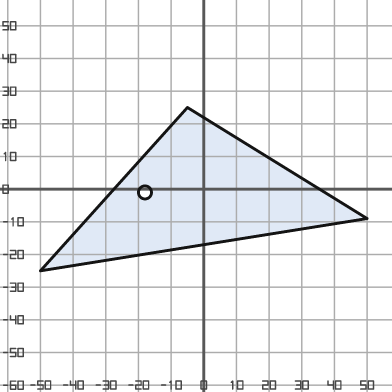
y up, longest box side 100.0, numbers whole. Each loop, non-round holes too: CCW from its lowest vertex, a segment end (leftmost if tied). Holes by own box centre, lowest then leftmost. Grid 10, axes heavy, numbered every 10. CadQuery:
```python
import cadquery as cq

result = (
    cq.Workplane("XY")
    .moveTo(-50.0, -25.0)
    .lineTo(50.0, -9.0)
    .lineTo(-5.0, 25.0)
    .close()
    .moveTo(-18.0, -1.0)
    .circle(2.0)
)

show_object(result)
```